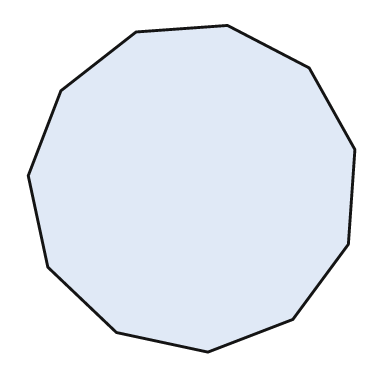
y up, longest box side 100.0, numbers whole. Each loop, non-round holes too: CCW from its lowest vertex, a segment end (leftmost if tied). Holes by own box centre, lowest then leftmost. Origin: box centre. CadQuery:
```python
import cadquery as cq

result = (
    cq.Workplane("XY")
    .moveTo(5.0, -50.0)
    .lineTo(31.0, -40.0)
    .lineTo(48.0, -17.0)
    .lineTo(50.0, 12.0)
    .lineTo(36.0, 37.0)
    .lineTo(11.0, 50.0)
    .lineTo(-17.0, 48.0)
    .lineTo(-40.0, 30.0)
    .lineTo(-50.0, 4.0)
    .lineTo(-44.0, -24.0)
    .lineTo(-23.0, -44.0)
    .close()
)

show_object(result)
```